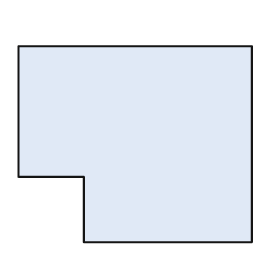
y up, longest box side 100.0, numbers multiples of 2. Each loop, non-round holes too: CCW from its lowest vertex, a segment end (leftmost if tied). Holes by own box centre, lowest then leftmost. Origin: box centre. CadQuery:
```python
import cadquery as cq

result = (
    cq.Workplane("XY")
    .moveTo(-22.0, -42.0)
    .lineTo(50.0, -42.0)
    .lineTo(50.0, 42.0)
    .lineTo(-50.0, 42.0)
    .lineTo(-50.0, -14.0)
    .lineTo(-22.0, -14.0)
    .close()
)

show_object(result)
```